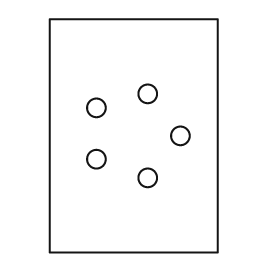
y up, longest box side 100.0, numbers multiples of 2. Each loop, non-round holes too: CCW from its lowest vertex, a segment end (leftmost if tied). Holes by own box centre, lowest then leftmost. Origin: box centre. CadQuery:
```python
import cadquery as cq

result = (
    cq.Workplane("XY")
    .moveTo(-36.0, -50.0)
    .lineTo(36.0, -50.0)
    .lineTo(36.0, 50.0)
    .lineTo(-36.0, 50.0)
    .close()
    .moveTo(6.0, -18.0)
    .circle(4.0)
    .moveTo(-16.0, -10.0)
    .circle(4.0)
    .moveTo(20.0, 0.0)
    .circle(4.0)
    .moveTo(-16.0, 12.0)
    .circle(4.0)
    .moveTo(6.0, 18.0)
    .circle(4.0)
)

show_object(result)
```